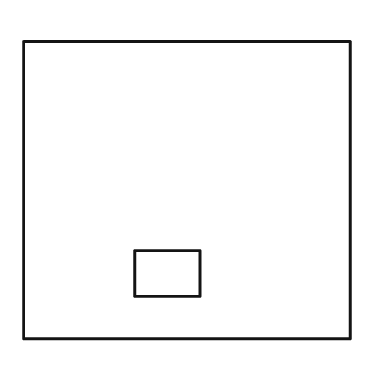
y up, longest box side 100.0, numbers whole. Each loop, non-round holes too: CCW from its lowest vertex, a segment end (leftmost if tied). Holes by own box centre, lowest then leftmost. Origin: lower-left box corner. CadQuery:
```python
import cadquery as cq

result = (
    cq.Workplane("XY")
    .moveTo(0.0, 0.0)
    .lineTo(100.0, 0.0)
    .lineTo(100.0, 91.0)
    .lineTo(0.0, 91.0)
    .close()
    .moveTo(34.0, 13.0)
    .lineTo(54.0, 13.0)
    .lineTo(54.0, 27.0)
    .lineTo(34.0, 27.0)
    .close()
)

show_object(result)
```